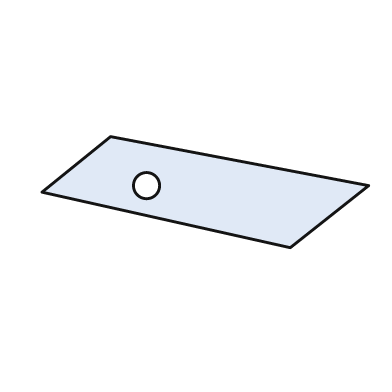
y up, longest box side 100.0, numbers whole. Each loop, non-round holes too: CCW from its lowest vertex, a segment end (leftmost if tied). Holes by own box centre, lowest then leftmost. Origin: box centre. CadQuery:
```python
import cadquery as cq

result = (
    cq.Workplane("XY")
    .moveTo(26.0, -17.0)
    .lineTo(50.0, 2.0)
    .lineTo(-29.0, 17.0)
    .lineTo(-50.0, 0.0)
    .close()
    .moveTo(-18.0, 2.0)
    .circle(4.0)
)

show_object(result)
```